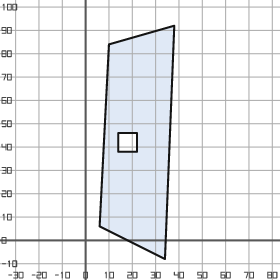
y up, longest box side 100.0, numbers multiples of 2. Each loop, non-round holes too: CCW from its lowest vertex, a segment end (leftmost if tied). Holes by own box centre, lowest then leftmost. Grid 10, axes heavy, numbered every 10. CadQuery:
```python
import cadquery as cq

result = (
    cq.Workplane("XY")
    .moveTo(34.0, -8.0)
    .lineTo(38.0, 92.0)
    .lineTo(10.0, 84.0)
    .lineTo(6.0, 6.0)
    .close()
    .moveTo(14.0, 38.0)
    .lineTo(22.0, 38.0)
    .lineTo(22.0, 46.0)
    .lineTo(14.0, 46.0)
    .close()
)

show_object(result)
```